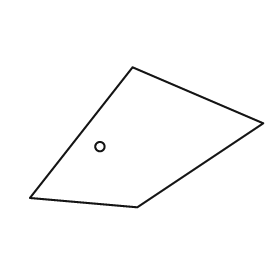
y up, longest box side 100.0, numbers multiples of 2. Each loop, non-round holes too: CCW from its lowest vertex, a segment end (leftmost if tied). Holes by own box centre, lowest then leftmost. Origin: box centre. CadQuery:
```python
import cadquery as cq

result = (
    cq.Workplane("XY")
    .moveTo(-4.0, -30.0)
    .lineTo(50.0, 6.0)
    .lineTo(-6.0, 30.0)
    .lineTo(-50.0, -26.0)
    .close()
    .moveTo(-20.0, -4.0)
    .circle(2.0)
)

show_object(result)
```